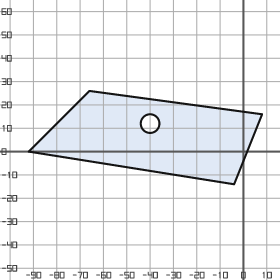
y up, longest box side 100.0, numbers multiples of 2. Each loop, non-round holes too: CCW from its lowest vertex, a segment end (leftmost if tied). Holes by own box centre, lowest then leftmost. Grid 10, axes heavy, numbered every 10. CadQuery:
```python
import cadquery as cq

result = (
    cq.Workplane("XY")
    .moveTo(-4.0, -14.0)
    .lineTo(8.0, 16.0)
    .lineTo(-66.0, 26.0)
    .lineTo(-92.0, 0.0)
    .close()
    .moveTo(-40.0, 12.0)
    .circle(4.0)
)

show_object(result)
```